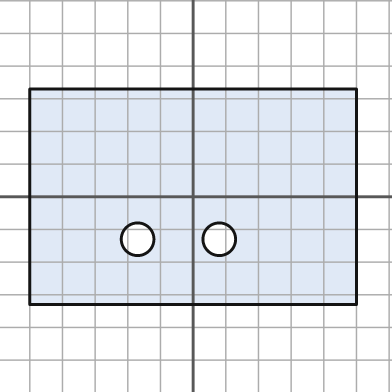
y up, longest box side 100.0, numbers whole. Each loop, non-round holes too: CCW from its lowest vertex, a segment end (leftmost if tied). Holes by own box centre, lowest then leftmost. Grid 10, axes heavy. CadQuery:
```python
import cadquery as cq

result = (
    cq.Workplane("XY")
    .moveTo(-50.0, -33.0)
    .lineTo(50.0, -33.0)
    .lineTo(50.0, 33.0)
    .lineTo(-50.0, 33.0)
    .close()
    .moveTo(-17.0, -13.0)
    .circle(5.0)
    .moveTo(8.0, -13.0)
    .circle(5.0)
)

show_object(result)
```